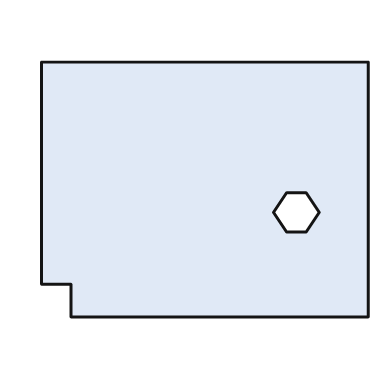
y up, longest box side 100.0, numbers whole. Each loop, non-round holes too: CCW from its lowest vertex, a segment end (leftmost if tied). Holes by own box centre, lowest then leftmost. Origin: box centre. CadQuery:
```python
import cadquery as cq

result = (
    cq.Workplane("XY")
    .moveTo(-41.0, -39.0)
    .lineTo(50.0, -39.0)
    .lineTo(50.0, 39.0)
    .lineTo(-50.0, 39.0)
    .lineTo(-50.0, -29.0)
    .lineTo(-41.0, -29.0)
    .close()
    .moveTo(25.0, -13.0)
    .lineTo(31.0, -13.0)
    .lineTo(35.0, -7.0)
    .lineTo(31.0, -1.0)
    .lineTo(25.0, -1.0)
    .lineTo(21.0, -7.0)
    .close()
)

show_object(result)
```